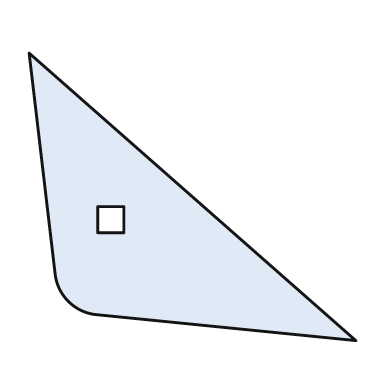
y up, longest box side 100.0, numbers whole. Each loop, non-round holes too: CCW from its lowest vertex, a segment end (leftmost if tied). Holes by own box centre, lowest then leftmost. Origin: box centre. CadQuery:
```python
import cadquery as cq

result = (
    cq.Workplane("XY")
    .moveTo(50.0, -44.0)
    .lineTo(-50.0, 44.0)
    .lineTo(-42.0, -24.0)
    .threePointArc((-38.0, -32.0), (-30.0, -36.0))
    .close()
    .moveTo(-29.0, -11.0)
    .lineTo(-21.0, -11.0)
    .lineTo(-21.0, -3.0)
    .lineTo(-29.0, -3.0)
    .close()
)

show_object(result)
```